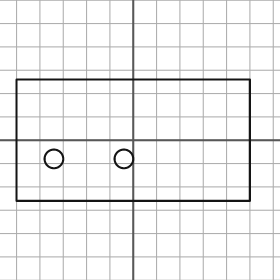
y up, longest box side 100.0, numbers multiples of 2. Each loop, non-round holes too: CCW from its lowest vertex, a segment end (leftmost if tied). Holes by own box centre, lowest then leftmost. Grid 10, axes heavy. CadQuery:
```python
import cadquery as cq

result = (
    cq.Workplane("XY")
    .moveTo(-50.0, -26.0)
    .lineTo(50.0, -26.0)
    .lineTo(50.0, 26.0)
    .lineTo(-50.0, 26.0)
    .close()
    .moveTo(-34.0, -8.0)
    .circle(4.0)
    .moveTo(-4.0, -8.0)
    .circle(4.0)
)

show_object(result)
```